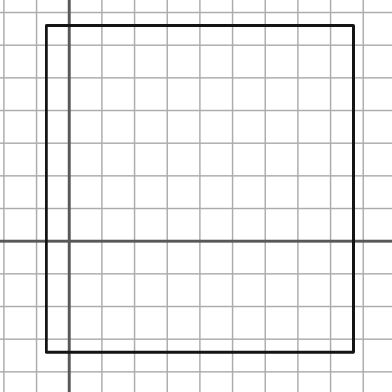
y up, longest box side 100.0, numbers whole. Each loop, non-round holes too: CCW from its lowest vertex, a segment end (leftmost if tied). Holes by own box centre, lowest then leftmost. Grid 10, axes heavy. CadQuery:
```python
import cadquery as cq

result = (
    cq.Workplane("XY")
    .moveTo(-7.0, -34.0)
    .lineTo(87.0, -34.0)
    .lineTo(87.0, 66.0)
    .lineTo(-7.0, 66.0)
    .close()
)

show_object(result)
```